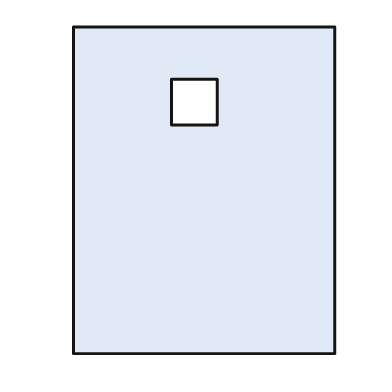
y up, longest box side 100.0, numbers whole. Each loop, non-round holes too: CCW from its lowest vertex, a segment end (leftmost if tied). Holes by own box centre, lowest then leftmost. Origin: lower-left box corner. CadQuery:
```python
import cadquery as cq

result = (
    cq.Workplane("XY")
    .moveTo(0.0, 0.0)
    .lineTo(80.0, 0.0)
    .lineTo(80.0, 100.0)
    .lineTo(0.0, 100.0)
    .close()
    .moveTo(30.0, 70.0)
    .lineTo(44.0, 70.0)
    .lineTo(44.0, 84.0)
    .lineTo(30.0, 84.0)
    .close()
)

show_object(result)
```